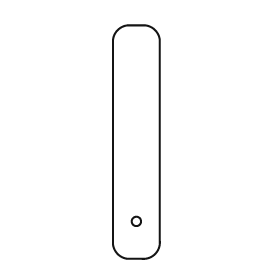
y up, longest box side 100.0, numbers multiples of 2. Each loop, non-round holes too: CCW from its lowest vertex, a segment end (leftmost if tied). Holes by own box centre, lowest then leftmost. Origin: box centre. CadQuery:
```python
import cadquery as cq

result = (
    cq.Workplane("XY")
    .moveTo(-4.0, -50.0)
    .lineTo(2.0, -50.0)
    .threePointArc((8.0, -48.0), (10.0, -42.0))
    .lineTo(10.0, 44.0)
    .threePointArc((8.0, 48.0), (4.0, 50.0))
    .lineTo(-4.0, 50.0)
    .threePointArc((-8.0, 48.0), (-10.0, 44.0))
    .lineTo(-10.0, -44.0)
    .threePointArc((-8.0, -48.0), (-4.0, -50.0))
    .close()
    .moveTo(0.0, -34.0)
    .circle(2.0)
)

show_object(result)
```